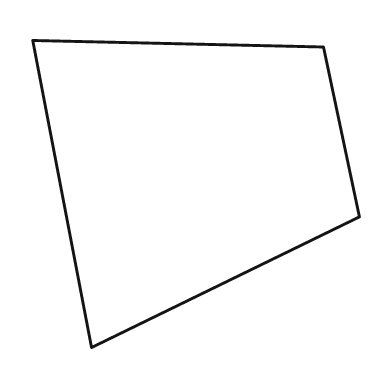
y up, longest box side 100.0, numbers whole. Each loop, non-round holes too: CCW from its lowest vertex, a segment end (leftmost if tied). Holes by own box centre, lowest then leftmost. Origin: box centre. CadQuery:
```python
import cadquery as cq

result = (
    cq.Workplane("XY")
    .moveTo(-32.0, -47.0)
    .lineTo(50.0, -7.0)
    .lineTo(39.0, 45.0)
    .lineTo(-50.0, 47.0)
    .close()
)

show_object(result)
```